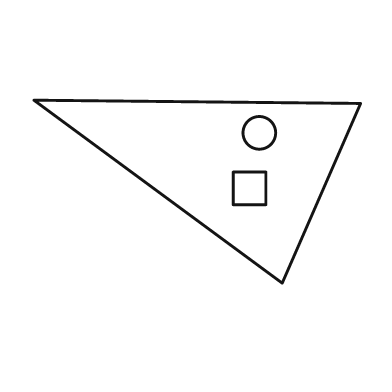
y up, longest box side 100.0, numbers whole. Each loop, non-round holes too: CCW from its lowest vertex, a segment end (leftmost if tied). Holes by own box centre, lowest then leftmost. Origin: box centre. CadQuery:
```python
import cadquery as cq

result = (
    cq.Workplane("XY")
    .moveTo(26.0, -28.0)
    .lineTo(50.0, 27.0)
    .lineTo(-50.0, 28.0)
    .close()
    .moveTo(11.0, -4.0)
    .lineTo(21.0, -4.0)
    .lineTo(21.0, 6.0)
    .lineTo(11.0, 6.0)
    .close()
    .moveTo(19.0, 18.0)
    .circle(5.0)
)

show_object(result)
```